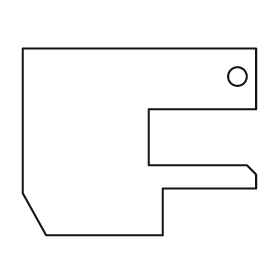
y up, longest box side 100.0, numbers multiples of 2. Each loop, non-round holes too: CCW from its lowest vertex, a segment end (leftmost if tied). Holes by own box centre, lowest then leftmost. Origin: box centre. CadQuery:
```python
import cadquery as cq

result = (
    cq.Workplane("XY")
    .moveTo(-40.0, -40.0)
    .lineTo(10.0, -40.0)
    .lineTo(10.0, -20.0)
    .lineTo(50.0, -20.0)
    .lineTo(50.0, -14.0)
    .lineTo(46.0, -10.0)
    .lineTo(4.0, -10.0)
    .lineTo(4.0, 14.0)
    .lineTo(50.0, 14.0)
    .lineTo(50.0, 40.0)
    .lineTo(-50.0, 40.0)
    .lineTo(-50.0, -22.0)
    .close()
    .moveTo(42.0, 28.0)
    .circle(4.0)
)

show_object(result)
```